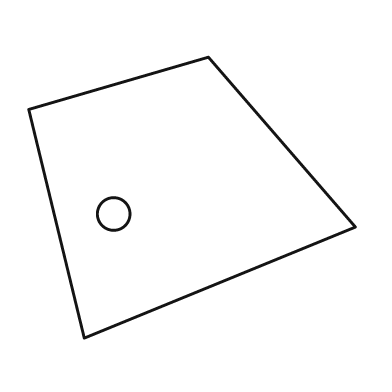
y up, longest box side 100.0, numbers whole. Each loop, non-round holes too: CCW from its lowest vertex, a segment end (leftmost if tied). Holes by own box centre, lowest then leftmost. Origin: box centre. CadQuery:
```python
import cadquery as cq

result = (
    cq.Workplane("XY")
    .moveTo(-33.0, -43.0)
    .lineTo(50.0, -9.0)
    .lineTo(5.0, 43.0)
    .lineTo(-50.0, 27.0)
    .close()
    .moveTo(-24.0, -5.0)
    .circle(5.0)
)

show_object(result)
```